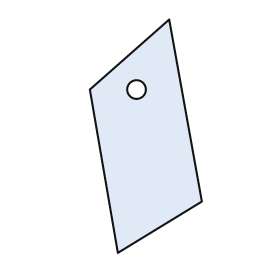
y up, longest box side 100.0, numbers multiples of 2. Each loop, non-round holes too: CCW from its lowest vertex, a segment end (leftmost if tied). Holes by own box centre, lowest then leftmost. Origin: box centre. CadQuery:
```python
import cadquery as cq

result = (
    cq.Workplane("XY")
    .moveTo(-12.0, -50.0)
    .lineTo(24.0, -28.0)
    .lineTo(10.0, 50.0)
    .lineTo(-24.0, 20.0)
    .close()
    .moveTo(-4.0, 20.0)
    .circle(4.0)
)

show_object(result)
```